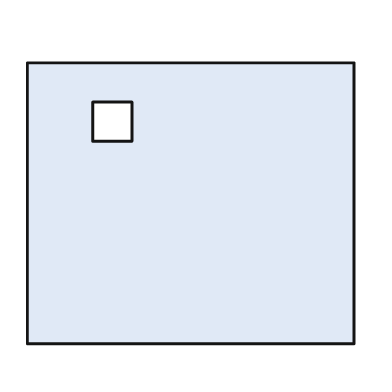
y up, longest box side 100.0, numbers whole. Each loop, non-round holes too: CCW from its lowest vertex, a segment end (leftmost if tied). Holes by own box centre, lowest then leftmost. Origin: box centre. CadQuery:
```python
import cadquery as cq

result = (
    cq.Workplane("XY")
    .moveTo(-50.0, -43.0)
    .lineTo(50.0, -43.0)
    .lineTo(50.0, 43.0)
    .lineTo(-50.0, 43.0)
    .close()
    .moveTo(-30.0, 19.0)
    .lineTo(-18.0, 19.0)
    .lineTo(-18.0, 31.0)
    .lineTo(-30.0, 31.0)
    .close()
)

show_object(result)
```